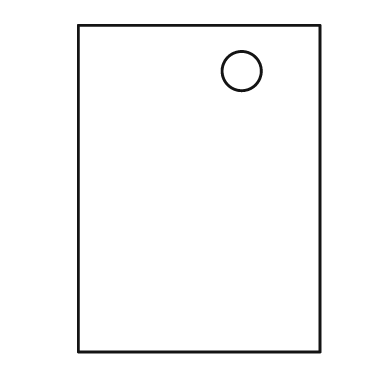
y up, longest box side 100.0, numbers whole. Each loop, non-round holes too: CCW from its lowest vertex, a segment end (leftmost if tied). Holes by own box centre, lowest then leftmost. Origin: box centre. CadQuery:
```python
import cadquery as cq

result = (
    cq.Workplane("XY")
    .moveTo(-37.0, -50.0)
    .lineTo(37.0, -50.0)
    .lineTo(37.0, 50.0)
    .lineTo(-37.0, 50.0)
    .close()
    .moveTo(13.0, 36.0)
    .circle(6.0)
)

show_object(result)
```